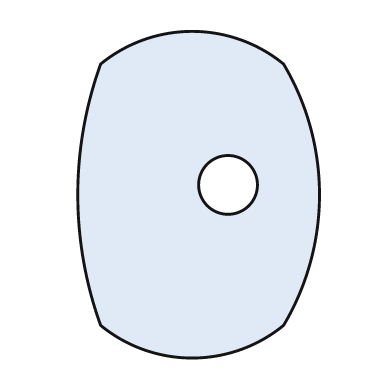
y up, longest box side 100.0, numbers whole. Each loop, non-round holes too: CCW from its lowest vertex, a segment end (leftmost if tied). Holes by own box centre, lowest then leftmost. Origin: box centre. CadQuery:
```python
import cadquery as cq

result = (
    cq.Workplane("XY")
    .moveTo(-30.0, -40.0)
    .threePointArc((-2.0, -50.0), (26.0, -40.0))
    .threePointArc((37.0, 0.0), (26.0, 40.0))
    .threePointArc((-2.0, 50.0), (-30.0, 40.0))
    .threePointArc((-37.0, 0.0), (-30.0, -40.0))
    .close()
    .moveTo(9.0, 3.0)
    .circle(9.0)
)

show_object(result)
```